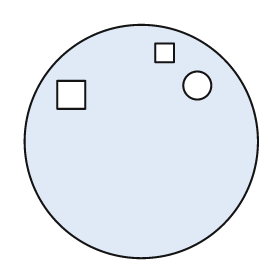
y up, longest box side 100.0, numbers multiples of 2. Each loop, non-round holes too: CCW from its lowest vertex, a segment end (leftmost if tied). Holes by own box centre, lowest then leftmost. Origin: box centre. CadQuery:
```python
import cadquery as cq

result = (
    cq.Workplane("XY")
    .moveTo(0.0, 0.0)
    .circle(50.0)
    .moveTo(-36.0, 14.0)
    .lineTo(-24.0, 14.0)
    .lineTo(-24.0, 26.0)
    .lineTo(-36.0, 26.0)
    .close()
    .moveTo(24.0, 24.0)
    .circle(6.0)
    .moveTo(6.0, 34.0)
    .lineTo(14.0, 34.0)
    .lineTo(14.0, 42.0)
    .lineTo(6.0, 42.0)
    .close()
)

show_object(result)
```